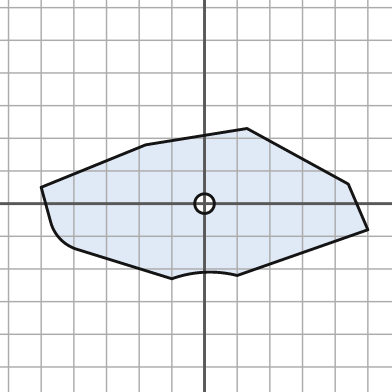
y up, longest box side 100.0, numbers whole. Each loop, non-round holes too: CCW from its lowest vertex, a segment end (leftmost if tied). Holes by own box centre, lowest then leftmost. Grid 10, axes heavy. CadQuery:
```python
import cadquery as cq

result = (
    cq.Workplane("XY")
    .moveTo(-10.0, -23.0)
    .threePointArc((0.0, -21.0), (10.0, -22.0))
    .lineTo(50.0, -8.0)
    .lineTo(44.0, 6.0)
    .lineTo(13.0, 23.0)
    .lineTo(-18.0, 18.0)
    .lineTo(-50.0, 5.0)
    .lineTo(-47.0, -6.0)
    .threePointArc((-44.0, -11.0), (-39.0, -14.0))
    .close()
    .moveTo(0.0, 0.0)
    .circle(3.0)
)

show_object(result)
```